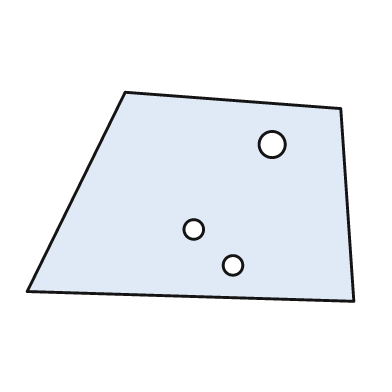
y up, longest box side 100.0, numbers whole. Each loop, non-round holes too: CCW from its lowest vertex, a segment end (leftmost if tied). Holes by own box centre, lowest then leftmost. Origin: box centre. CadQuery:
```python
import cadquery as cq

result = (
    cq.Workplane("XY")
    .moveTo(50.0, -32.0)
    .lineTo(46.0, 27.0)
    .lineTo(-20.0, 32.0)
    .lineTo(-50.0, -29.0)
    .close()
    .moveTo(13.0, -21.0)
    .circle(3.0)
    .moveTo(1.0, -10.0)
    .circle(3.0)
    .moveTo(25.0, 16.0)
    .circle(4.0)
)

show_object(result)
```